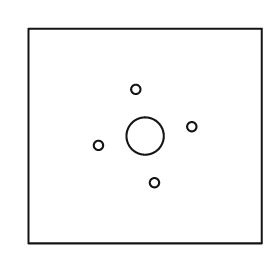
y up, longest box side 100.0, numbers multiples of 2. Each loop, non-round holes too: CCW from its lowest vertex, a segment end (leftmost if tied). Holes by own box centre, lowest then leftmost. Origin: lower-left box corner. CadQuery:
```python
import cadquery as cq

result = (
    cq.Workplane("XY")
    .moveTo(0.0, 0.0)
    .lineTo(100.0, 0.0)
    .lineTo(100.0, 92.0)
    .lineTo(0.0, 92.0)
    .close()
    .moveTo(54.0, 26.0)
    .circle(2.0)
    .moveTo(30.0, 42.0)
    .circle(2.0)
    .moveTo(50.0, 46.0)
    .circle(8.0)
    .moveTo(70.0, 50.0)
    .circle(2.0)
    .moveTo(46.0, 66.0)
    .circle(2.0)
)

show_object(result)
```